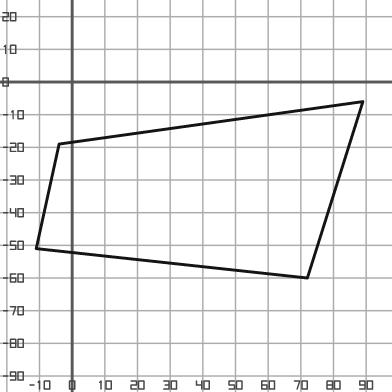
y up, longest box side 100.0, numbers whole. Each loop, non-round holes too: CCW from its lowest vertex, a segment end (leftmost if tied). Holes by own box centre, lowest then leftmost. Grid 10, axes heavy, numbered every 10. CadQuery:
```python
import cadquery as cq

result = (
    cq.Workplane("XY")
    .moveTo(72.0, -60.0)
    .lineTo(89.0, -6.0)
    .lineTo(-4.0, -19.0)
    .lineTo(-11.0, -51.0)
    .close()
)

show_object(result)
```